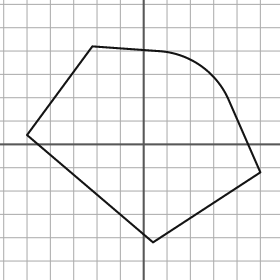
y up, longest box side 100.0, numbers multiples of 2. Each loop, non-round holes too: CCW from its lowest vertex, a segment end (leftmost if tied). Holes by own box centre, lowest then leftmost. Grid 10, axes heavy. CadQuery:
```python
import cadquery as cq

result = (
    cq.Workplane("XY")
    .moveTo(4.0, -42.0)
    .lineTo(50.0, -12.0)
    .lineTo(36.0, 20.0)
    .threePointArc((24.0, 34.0), (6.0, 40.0))
    .lineTo(-22.0, 42.0)
    .lineTo(-50.0, 4.0)
    .close()
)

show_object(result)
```